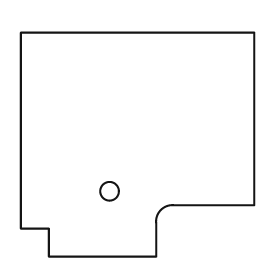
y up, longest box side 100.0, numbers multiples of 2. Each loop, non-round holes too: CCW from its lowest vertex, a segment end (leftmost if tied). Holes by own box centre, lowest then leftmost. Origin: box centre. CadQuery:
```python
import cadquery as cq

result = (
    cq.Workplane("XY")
    .moveTo(-38.0, -48.0)
    .lineTo(8.0, -48.0)
    .lineTo(8.0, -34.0)
    .threePointArc((10.0, -28.0), (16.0, -26.0))
    .lineTo(50.0, -26.0)
    .lineTo(50.0, 48.0)
    .lineTo(-50.0, 48.0)
    .lineTo(-50.0, -36.0)
    .lineTo(-38.0, -36.0)
    .close()
    .moveTo(-12.0, -20.0)
    .circle(4.0)
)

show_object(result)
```